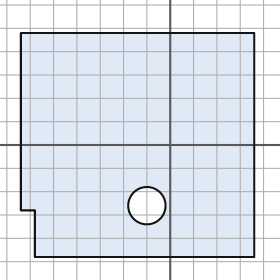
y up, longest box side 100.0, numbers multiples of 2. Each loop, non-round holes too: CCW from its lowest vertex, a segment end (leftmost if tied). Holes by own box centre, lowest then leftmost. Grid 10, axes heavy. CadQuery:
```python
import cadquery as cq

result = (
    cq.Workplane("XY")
    .moveTo(-58.0, -48.0)
    .lineTo(36.0, -48.0)
    .lineTo(36.0, 48.0)
    .lineTo(-64.0, 48.0)
    .lineTo(-64.0, -28.0)
    .lineTo(-58.0, -28.0)
    .close()
    .moveTo(-10.0, -26.0)
    .circle(8.0)
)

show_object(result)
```